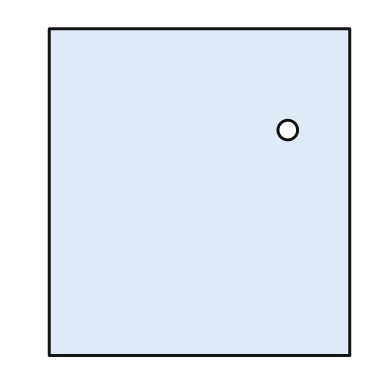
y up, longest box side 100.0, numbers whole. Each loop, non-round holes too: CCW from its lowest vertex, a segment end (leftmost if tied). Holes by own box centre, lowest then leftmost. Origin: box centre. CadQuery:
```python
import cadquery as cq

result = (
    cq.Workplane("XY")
    .moveTo(-46.0, -50.0)
    .lineTo(46.0, -50.0)
    .lineTo(46.0, 50.0)
    .lineTo(-46.0, 50.0)
    .close()
    .moveTo(27.0, 19.0)
    .circle(3.0)
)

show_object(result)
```